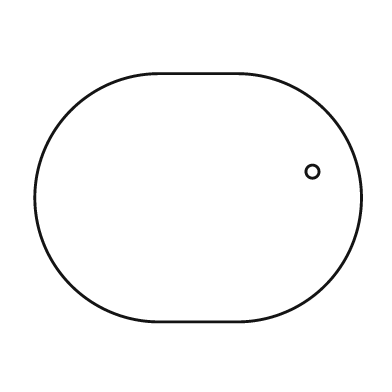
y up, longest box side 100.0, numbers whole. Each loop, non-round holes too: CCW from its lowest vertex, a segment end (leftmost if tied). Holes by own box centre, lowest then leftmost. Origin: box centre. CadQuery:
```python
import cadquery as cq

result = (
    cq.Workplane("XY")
    .moveTo(-12.0, -38.0)
    .lineTo(12.0, -38.0)
    .threePointArc((50.0, 0.0), (12.0, 38.0))
    .lineTo(-12.0, 38.0)
    .threePointArc((-50.0, 0.0), (-12.0, -38.0))
    .close()
    .moveTo(35.0, 8.0)
    .circle(2.0)
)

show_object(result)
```